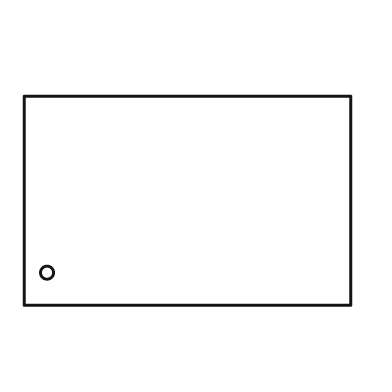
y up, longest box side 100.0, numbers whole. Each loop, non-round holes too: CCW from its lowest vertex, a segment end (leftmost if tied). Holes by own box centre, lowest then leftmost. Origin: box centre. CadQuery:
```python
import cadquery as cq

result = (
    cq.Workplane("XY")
    .moveTo(-50.0, -32.0)
    .lineTo(50.0, -32.0)
    .lineTo(50.0, 32.0)
    .lineTo(-50.0, 32.0)
    .close()
    .moveTo(-43.0, -22.0)
    .circle(2.0)
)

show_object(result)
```